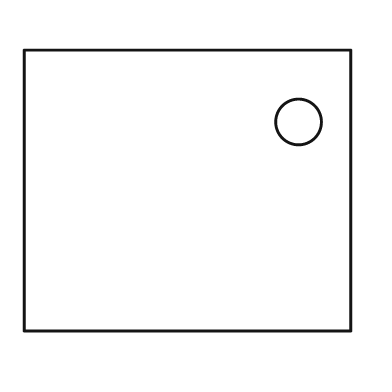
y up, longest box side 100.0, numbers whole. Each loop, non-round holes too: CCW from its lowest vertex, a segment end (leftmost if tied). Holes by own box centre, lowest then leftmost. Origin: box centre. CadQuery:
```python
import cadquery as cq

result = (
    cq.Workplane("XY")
    .moveTo(-50.0, -43.0)
    .lineTo(50.0, -43.0)
    .lineTo(50.0, 43.0)
    .lineTo(-50.0, 43.0)
    .close()
    .moveTo(34.0, 21.0)
    .circle(7.0)
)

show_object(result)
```